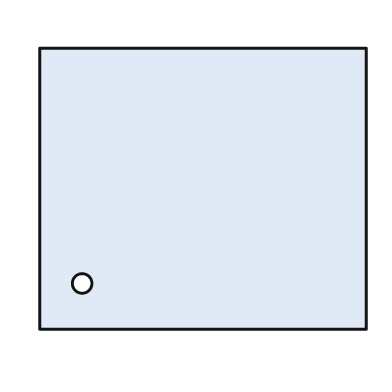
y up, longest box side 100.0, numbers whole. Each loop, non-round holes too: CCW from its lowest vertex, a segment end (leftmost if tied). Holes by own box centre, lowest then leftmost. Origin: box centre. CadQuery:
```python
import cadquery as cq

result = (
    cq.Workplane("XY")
    .moveTo(-50.0, -43.0)
    .lineTo(50.0, -43.0)
    .lineTo(50.0, 43.0)
    .lineTo(-50.0, 43.0)
    .close()
    .moveTo(-37.0, -29.0)
    .circle(3.0)
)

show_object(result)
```